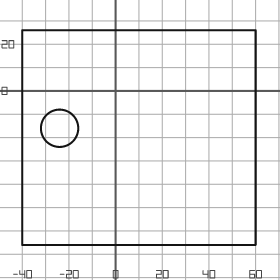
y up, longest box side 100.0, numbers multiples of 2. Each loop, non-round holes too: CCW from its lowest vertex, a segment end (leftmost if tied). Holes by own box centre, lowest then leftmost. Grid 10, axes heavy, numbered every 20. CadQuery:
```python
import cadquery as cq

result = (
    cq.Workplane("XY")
    .moveTo(-40.0, -66.0)
    .lineTo(60.0, -66.0)
    .lineTo(60.0, 26.0)
    .lineTo(-40.0, 26.0)
    .close()
    .moveTo(-24.0, -16.0)
    .circle(8.0)
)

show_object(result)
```